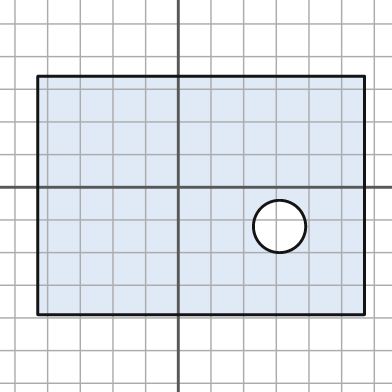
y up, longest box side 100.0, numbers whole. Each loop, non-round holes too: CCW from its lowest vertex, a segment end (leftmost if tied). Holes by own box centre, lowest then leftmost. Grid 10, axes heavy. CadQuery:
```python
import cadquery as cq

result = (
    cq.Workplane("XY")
    .moveTo(-43.0, -39.0)
    .lineTo(57.0, -39.0)
    .lineTo(57.0, 34.0)
    .lineTo(-43.0, 34.0)
    .close()
    .moveTo(31.0, -12.0)
    .circle(8.0)
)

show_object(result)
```